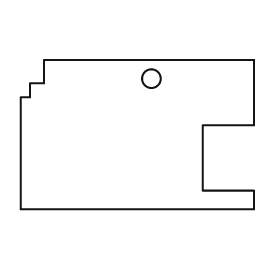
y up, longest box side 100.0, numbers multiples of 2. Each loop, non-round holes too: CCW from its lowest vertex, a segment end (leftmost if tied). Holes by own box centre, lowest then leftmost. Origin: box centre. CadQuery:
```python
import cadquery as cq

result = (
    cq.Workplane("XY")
    .moveTo(-50.0, -32.0)
    .lineTo(50.0, -32.0)
    .lineTo(50.0, -24.0)
    .lineTo(28.0, -24.0)
    .lineTo(28.0, 4.0)
    .lineTo(50.0, 4.0)
    .lineTo(50.0, 32.0)
    .lineTo(-40.0, 32.0)
    .lineTo(-40.0, 22.0)
    .lineTo(-46.0, 22.0)
    .lineTo(-46.0, 16.0)
    .lineTo(-50.0, 16.0)
    .close()
    .moveTo(6.0, 24.0)
    .circle(4.0)
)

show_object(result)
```